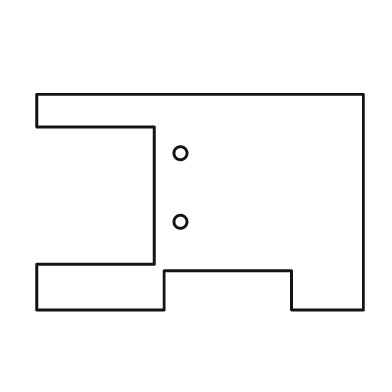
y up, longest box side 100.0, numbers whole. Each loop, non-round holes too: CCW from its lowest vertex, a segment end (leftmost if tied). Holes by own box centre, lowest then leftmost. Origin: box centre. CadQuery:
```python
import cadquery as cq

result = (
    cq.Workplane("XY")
    .moveTo(-50.0, -33.0)
    .lineTo(-11.0, -33.0)
    .lineTo(-11.0, -21.0)
    .lineTo(28.0, -21.0)
    .lineTo(28.0, -33.0)
    .lineTo(50.0, -33.0)
    .lineTo(50.0, 33.0)
    .lineTo(-50.0, 33.0)
    .lineTo(-50.0, 23.0)
    .lineTo(-14.0, 23.0)
    .lineTo(-14.0, -19.0)
    .lineTo(-50.0, -19.0)
    .close()
    .moveTo(-6.0, -6.0)
    .circle(2.0)
    .moveTo(-6.0, 15.0)
    .circle(2.0)
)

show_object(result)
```